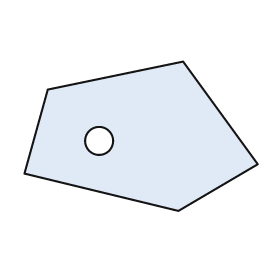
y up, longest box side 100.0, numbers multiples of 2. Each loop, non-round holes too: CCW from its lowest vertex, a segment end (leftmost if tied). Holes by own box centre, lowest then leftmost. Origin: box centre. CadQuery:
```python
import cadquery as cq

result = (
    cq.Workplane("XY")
    .moveTo(16.0, -32.0)
    .lineTo(50.0, -12.0)
    .lineTo(18.0, 32.0)
    .lineTo(-40.0, 20.0)
    .lineTo(-50.0, -16.0)
    .close()
    .moveTo(-18.0, -2.0)
    .circle(6.0)
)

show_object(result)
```